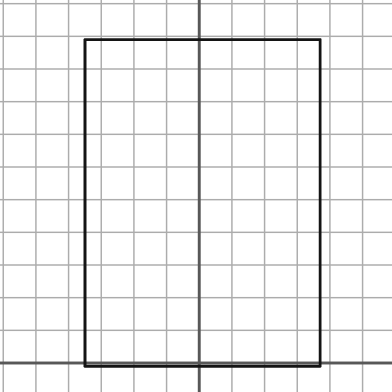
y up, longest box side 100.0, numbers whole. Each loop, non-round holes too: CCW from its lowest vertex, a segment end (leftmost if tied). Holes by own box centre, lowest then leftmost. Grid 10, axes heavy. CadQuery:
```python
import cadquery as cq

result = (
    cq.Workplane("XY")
    .moveTo(-35.0, -1.0)
    .lineTo(37.0, -1.0)
    .lineTo(37.0, 99.0)
    .lineTo(-35.0, 99.0)
    .close()
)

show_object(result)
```